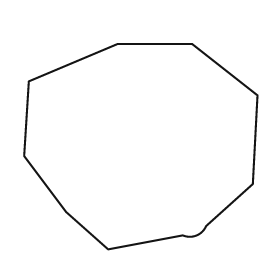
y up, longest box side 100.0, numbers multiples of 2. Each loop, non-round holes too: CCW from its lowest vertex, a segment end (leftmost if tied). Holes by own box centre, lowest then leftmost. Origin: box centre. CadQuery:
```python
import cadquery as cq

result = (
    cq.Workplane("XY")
    .moveTo(-14.0, -44.0)
    .lineTo(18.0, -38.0)
    .threePointArc((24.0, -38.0), (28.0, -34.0))
    .lineTo(48.0, -16.0)
    .lineTo(50.0, 22.0)
    .lineTo(22.0, 44.0)
    .lineTo(-10.0, 44.0)
    .lineTo(-48.0, 28.0)
    .lineTo(-50.0, -4.0)
    .lineTo(-32.0, -28.0)
    .close()
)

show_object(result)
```